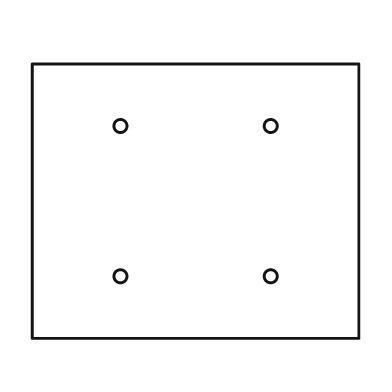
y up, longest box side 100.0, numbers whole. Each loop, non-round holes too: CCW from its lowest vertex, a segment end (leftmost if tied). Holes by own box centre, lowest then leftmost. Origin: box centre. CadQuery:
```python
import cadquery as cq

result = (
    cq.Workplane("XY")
    .moveTo(-50.0, -42.0)
    .lineTo(50.0, -42.0)
    .lineTo(50.0, 42.0)
    .lineTo(-50.0, 42.0)
    .close()
    .moveTo(-23.0, -23.0)
    .circle(2.0)
    .moveTo(23.0, -23.0)
    .circle(2.0)
    .moveTo(-23.0, 23.0)
    .circle(2.0)
    .moveTo(23.0, 23.0)
    .circle(2.0)
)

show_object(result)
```